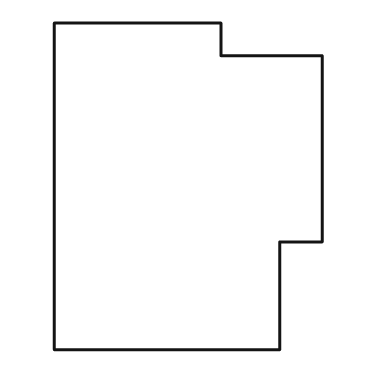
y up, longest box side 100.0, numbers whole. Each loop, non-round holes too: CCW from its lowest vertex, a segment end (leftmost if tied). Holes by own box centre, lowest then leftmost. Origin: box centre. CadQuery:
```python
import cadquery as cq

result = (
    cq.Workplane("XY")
    .moveTo(-41.0, -50.0)
    .lineTo(28.0, -50.0)
    .lineTo(28.0, -17.0)
    .lineTo(41.0, -17.0)
    .lineTo(41.0, 40.0)
    .lineTo(10.0, 40.0)
    .lineTo(10.0, 50.0)
    .lineTo(-41.0, 50.0)
    .close()
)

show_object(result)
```